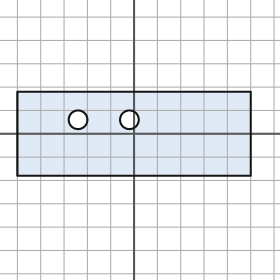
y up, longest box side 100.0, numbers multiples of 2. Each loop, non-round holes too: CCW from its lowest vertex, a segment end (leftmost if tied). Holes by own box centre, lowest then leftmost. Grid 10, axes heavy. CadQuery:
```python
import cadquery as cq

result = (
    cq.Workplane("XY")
    .moveTo(-50.0, -18.0)
    .lineTo(50.0, -18.0)
    .lineTo(50.0, 18.0)
    .lineTo(-50.0, 18.0)
    .close()
    .moveTo(-24.0, 6.0)
    .circle(4.0)
    .moveTo(-2.0, 6.0)
    .circle(4.0)
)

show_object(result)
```